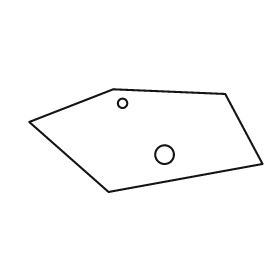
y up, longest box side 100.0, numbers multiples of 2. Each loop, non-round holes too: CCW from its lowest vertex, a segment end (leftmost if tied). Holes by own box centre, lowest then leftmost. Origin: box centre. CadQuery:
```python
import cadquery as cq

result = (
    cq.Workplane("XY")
    .moveTo(-16.0, -22.0)
    .lineTo(50.0, -10.0)
    .lineTo(34.0, 20.0)
    .lineTo(-14.0, 22.0)
    .lineTo(-50.0, 8.0)
    .close()
    .moveTo(8.0, -6.0)
    .circle(4.0)
    .moveTo(-10.0, 16.0)
    .circle(2.0)
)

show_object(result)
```